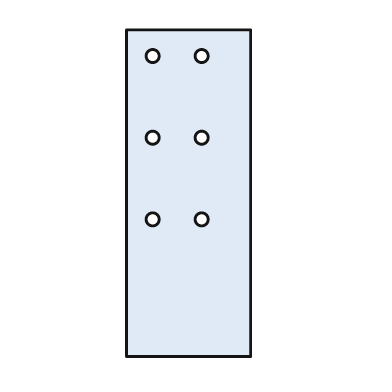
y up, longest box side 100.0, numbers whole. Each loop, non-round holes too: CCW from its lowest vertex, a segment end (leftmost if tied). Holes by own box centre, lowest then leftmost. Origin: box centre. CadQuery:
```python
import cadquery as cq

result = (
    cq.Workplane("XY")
    .moveTo(-19.0, -50.0)
    .lineTo(19.0, -50.0)
    .lineTo(19.0, 50.0)
    .lineTo(-19.0, 50.0)
    .close()
    .moveTo(-11.0, -8.0)
    .circle(2.0)
    .moveTo(4.0, -8.0)
    .circle(2.0)
    .moveTo(-11.0, 17.0)
    .circle(2.0)
    .moveTo(4.0, 17.0)
    .circle(2.0)
    .moveTo(-11.0, 42.0)
    .circle(2.0)
    .moveTo(4.0, 42.0)
    .circle(2.0)
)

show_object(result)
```